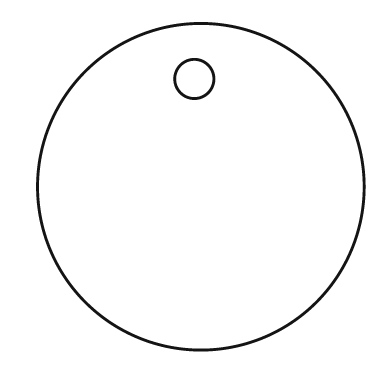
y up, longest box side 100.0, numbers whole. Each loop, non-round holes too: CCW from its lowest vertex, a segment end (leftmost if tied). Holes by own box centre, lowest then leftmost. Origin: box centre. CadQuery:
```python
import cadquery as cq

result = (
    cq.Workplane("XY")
    .moveTo(0.0, 0.0)
    .circle(50.0)
    .moveTo(-2.0, 33.0)
    .circle(6.0)
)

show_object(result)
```